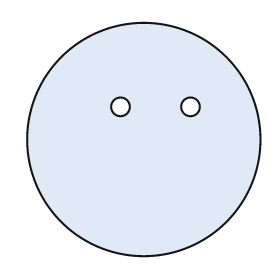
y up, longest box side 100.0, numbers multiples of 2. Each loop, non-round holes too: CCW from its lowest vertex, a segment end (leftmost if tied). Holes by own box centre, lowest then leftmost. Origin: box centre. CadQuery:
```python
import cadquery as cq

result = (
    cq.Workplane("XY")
    .moveTo(0.0, 0.0)
    .circle(50.0)
    .moveTo(-10.0, 14.0)
    .circle(4.0)
    .moveTo(20.0, 14.0)
    .circle(4.0)
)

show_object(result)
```